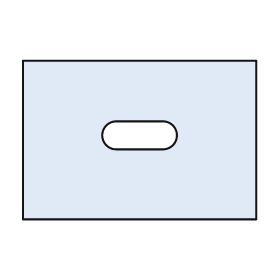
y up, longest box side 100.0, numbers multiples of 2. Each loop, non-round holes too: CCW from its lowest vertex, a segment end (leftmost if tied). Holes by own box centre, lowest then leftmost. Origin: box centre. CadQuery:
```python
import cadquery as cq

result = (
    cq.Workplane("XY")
    .moveTo(-50.0, -34.0)
    .lineTo(50.0, -34.0)
    .lineTo(50.0, 34.0)
    .lineTo(-50.0, 34.0)
    .close()
    .moveTo(-10.0, -4.0)
    .lineTo(10.0, -4.0)
    .threePointArc((16.0, 2.0), (10.0, 8.0))
    .lineTo(-10.0, 8.0)
    .threePointArc((-16.0, 2.0), (-10.0, -4.0))
    .close()
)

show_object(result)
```